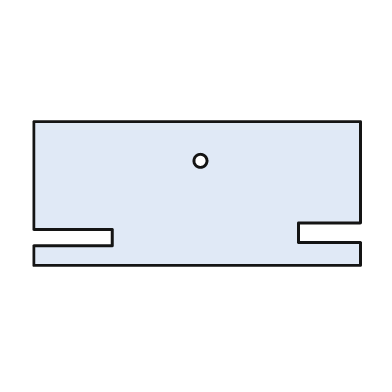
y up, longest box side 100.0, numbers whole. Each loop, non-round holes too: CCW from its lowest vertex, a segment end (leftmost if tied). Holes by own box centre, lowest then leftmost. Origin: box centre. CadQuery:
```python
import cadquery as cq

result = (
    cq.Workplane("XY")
    .moveTo(-50.0, -22.0)
    .lineTo(50.0, -22.0)
    .lineTo(50.0, -15.0)
    .lineTo(31.0, -15.0)
    .lineTo(31.0, -9.0)
    .lineTo(50.0, -9.0)
    .lineTo(50.0, 22.0)
    .lineTo(-50.0, 22.0)
    .lineTo(-50.0, -11.0)
    .lineTo(-26.0, -11.0)
    .lineTo(-26.0, -16.0)
    .lineTo(-50.0, -16.0)
    .close()
    .moveTo(1.0, 10.0)
    .circle(2.0)
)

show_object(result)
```